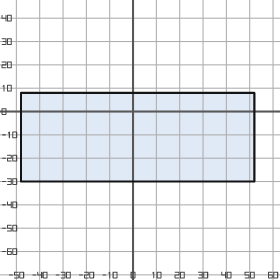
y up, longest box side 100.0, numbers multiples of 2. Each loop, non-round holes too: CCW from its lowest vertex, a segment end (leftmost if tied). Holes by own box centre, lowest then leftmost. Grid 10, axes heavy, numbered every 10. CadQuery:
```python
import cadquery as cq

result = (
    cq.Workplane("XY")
    .moveTo(-48.0, -30.0)
    .lineTo(52.0, -30.0)
    .lineTo(52.0, 8.0)
    .lineTo(-48.0, 8.0)
    .close()
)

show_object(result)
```